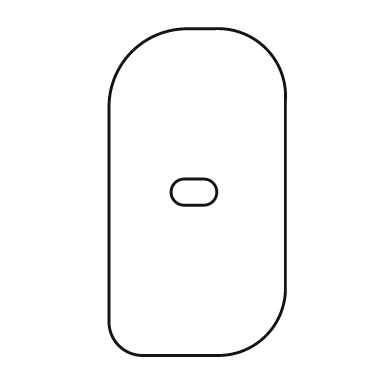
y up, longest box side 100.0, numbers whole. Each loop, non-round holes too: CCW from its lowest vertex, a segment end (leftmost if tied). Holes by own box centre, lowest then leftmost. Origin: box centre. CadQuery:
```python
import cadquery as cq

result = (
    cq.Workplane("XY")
    .moveTo(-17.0, -50.0)
    .lineTo(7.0, -50.0)
    .threePointArc((21.0, -44.0), (27.0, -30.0))
    .lineTo(27.0, 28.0)
    .threePointArc((21.0, 44.0), (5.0, 50.0))
    .lineTo(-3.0, 50.0)
    .threePointArc((-20.0, 43.0), (-27.0, 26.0))
    .lineTo(-27.0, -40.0)
    .threePointArc((-24.0, -47.0), (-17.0, -50.0))
    .close()
    .moveTo(-4.0, -4.0)
    .lineTo(2.0, -4.0)
    .threePointArc((6.0, 0.0), (2.0, 4.0))
    .lineTo(-4.0, 4.0)
    .threePointArc((-8.0, 0.0), (-4.0, -4.0))
    .close()
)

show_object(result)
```